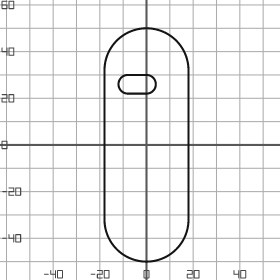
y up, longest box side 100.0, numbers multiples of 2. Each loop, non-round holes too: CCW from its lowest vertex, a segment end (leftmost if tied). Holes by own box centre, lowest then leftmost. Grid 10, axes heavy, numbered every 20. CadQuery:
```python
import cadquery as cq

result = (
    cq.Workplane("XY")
    .moveTo(-18.0, -32.0)
    .threePointArc((0.0, -50.0), (18.0, -32.0))
    .lineTo(18.0, 32.0)
    .threePointArc((0.0, 50.0), (-18.0, 32.0))
    .close()
    .moveTo(-8.0, 22.0)
    .lineTo(0.0, 22.0)
    .threePointArc((4.0, 26.0), (0.0, 30.0))
    .lineTo(-8.0, 30.0)
    .threePointArc((-12.0, 26.0), (-8.0, 22.0))
    .close()
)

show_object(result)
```